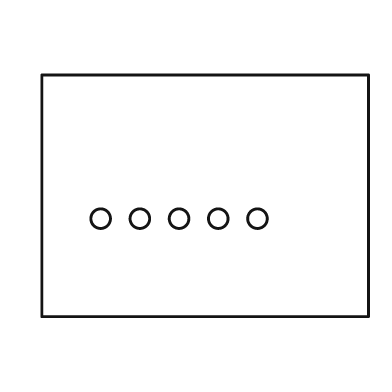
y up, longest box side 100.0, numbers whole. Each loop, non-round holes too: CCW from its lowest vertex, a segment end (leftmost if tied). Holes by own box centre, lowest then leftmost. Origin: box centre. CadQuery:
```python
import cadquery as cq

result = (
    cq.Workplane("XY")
    .moveTo(-50.0, -37.0)
    .lineTo(50.0, -37.0)
    .lineTo(50.0, 37.0)
    .lineTo(-50.0, 37.0)
    .close()
    .moveTo(-32.0, -7.0)
    .circle(3.0)
    .moveTo(-20.0, -7.0)
    .circle(3.0)
    .moveTo(-8.0, -7.0)
    .circle(3.0)
    .moveTo(4.0, -7.0)
    .circle(3.0)
    .moveTo(16.0, -7.0)
    .circle(3.0)
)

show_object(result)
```